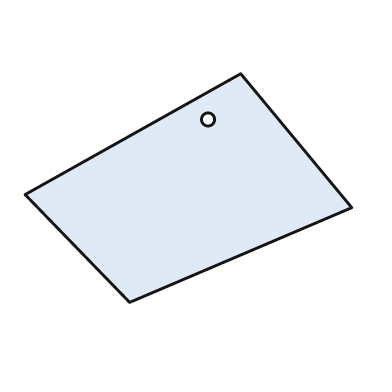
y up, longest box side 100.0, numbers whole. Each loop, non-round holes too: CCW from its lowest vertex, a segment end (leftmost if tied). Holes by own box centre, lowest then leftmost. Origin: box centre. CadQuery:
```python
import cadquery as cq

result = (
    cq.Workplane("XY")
    .moveTo(-18.0, -35.0)
    .lineTo(50.0, -6.0)
    .lineTo(16.0, 35.0)
    .lineTo(-50.0, -2.0)
    .close()
    .moveTo(6.0, 21.0)
    .circle(2.0)
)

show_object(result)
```